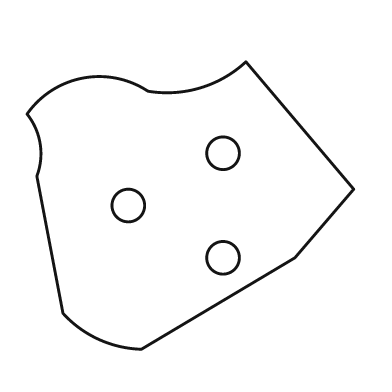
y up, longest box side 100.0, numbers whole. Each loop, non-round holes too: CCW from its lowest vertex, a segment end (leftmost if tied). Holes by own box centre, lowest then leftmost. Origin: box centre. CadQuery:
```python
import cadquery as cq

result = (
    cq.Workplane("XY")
    .moveTo(-15.0, -44.0)
    .lineTo(32.0, -16.0)
    .lineTo(50.0, 5.0)
    .lineTo(17.0, 44.0)
    .threePointArc((3.0, 36.0), (-13.0, 35.0))
    .threePointArc((-33.0, 39.0), (-50.0, 28.0))
    .threePointArc((-46.0, 19.0), (-47.0, 9.0))
    .lineTo(-39.0, -33.0)
    .threePointArc((-28.0, -41.0), (-15.0, -44.0))
    .close()
    .moveTo(10.0, -16.0)
    .circle(5.0)
    .moveTo(-19.0, 0.0)
    .circle(5.0)
    .moveTo(10.0, 16.0)
    .circle(5.0)
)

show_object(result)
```